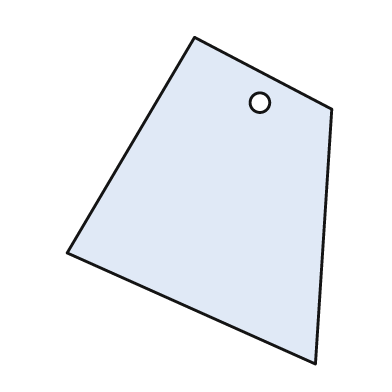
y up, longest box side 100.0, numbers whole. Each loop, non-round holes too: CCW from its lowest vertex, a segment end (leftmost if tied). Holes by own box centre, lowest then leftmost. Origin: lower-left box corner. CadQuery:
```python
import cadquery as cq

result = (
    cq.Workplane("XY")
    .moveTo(76.0, 0.0)
    .lineTo(81.0, 78.0)
    .lineTo(39.0, 100.0)
    .lineTo(0.0, 34.0)
    .close()
    .moveTo(59.0, 80.0)
    .circle(3.0)
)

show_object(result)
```